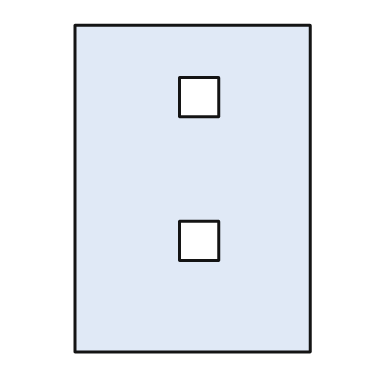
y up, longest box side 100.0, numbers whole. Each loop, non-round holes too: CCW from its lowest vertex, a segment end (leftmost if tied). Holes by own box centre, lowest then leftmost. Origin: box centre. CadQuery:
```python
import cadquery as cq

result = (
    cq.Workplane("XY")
    .moveTo(-36.0, -50.0)
    .lineTo(36.0, -50.0)
    .lineTo(36.0, 50.0)
    .lineTo(-36.0, 50.0)
    .close()
    .moveTo(-4.0, -22.0)
    .lineTo(8.0, -22.0)
    .lineTo(8.0, -10.0)
    .lineTo(-4.0, -10.0)
    .close()
    .moveTo(-4.0, 22.0)
    .lineTo(8.0, 22.0)
    .lineTo(8.0, 34.0)
    .lineTo(-4.0, 34.0)
    .close()
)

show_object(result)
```